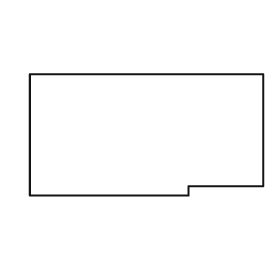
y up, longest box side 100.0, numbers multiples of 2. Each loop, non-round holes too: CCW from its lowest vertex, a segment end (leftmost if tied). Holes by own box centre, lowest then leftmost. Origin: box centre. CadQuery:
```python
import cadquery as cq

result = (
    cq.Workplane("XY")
    .moveTo(-50.0, -26.0)
    .lineTo(18.0, -26.0)
    .lineTo(18.0, -22.0)
    .lineTo(50.0, -22.0)
    .lineTo(50.0, 26.0)
    .lineTo(-50.0, 26.0)
    .close()
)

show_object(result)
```